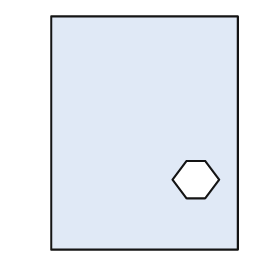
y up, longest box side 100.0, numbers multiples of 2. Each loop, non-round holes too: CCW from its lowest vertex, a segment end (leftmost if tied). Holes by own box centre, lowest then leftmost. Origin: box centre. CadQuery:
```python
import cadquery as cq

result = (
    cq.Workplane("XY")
    .moveTo(-40.0, -50.0)
    .lineTo(40.0, -50.0)
    .lineTo(40.0, 50.0)
    .lineTo(-40.0, 50.0)
    .close()
    .moveTo(18.0, -28.0)
    .lineTo(26.0, -28.0)
    .lineTo(32.0, -20.0)
    .lineTo(26.0, -12.0)
    .lineTo(18.0, -12.0)
    .lineTo(12.0, -20.0)
    .close()
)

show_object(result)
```